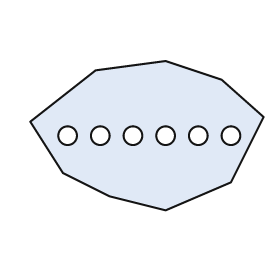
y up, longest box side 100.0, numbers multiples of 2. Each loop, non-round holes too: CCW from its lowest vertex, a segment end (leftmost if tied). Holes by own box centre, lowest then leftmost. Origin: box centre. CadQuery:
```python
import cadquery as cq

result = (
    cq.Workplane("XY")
    .moveTo(8.0, -32.0)
    .lineTo(36.0, -20.0)
    .lineTo(50.0, 8.0)
    .lineTo(32.0, 24.0)
    .lineTo(8.0, 32.0)
    .lineTo(-22.0, 28.0)
    .lineTo(-50.0, 6.0)
    .lineTo(-36.0, -16.0)
    .lineTo(-16.0, -26.0)
    .close()
    .moveTo(-34.0, 0.0)
    .circle(4.0)
    .moveTo(-20.0, 0.0)
    .circle(4.0)
    .moveTo(-6.0, 0.0)
    .circle(4.0)
    .moveTo(8.0, 0.0)
    .circle(4.0)
    .moveTo(22.0, 0.0)
    .circle(4.0)
    .moveTo(36.0, 0.0)
    .circle(4.0)
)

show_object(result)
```